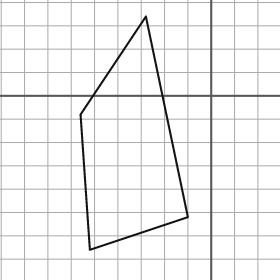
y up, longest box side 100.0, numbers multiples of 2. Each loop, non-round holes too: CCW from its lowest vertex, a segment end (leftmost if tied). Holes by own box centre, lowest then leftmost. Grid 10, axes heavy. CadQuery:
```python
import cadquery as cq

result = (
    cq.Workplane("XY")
    .moveTo(-52.0, -66.0)
    .lineTo(-10.0, -52.0)
    .lineTo(-28.0, 34.0)
    .lineTo(-56.0, -8.0)
    .close()
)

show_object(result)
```